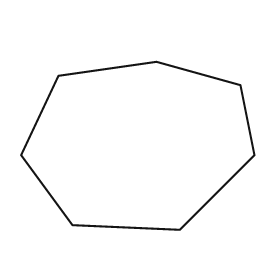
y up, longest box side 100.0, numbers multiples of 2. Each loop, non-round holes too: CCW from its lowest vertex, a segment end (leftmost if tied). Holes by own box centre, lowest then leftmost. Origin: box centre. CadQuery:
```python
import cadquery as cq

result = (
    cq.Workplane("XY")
    .moveTo(18.0, -36.0)
    .lineTo(50.0, -4.0)
    .lineTo(44.0, 26.0)
    .lineTo(8.0, 36.0)
    .lineTo(-34.0, 30.0)
    .lineTo(-50.0, -4.0)
    .lineTo(-28.0, -34.0)
    .close()
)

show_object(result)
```